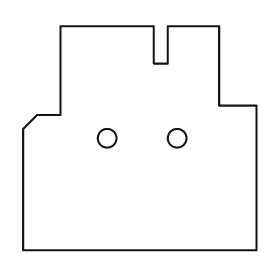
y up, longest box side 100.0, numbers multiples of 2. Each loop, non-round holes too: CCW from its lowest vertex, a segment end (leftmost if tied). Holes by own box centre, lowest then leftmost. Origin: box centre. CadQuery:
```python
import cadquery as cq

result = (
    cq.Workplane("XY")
    .moveTo(-50.0, -48.0)
    .lineTo(50.0, -48.0)
    .lineTo(50.0, 14.0)
    .lineTo(34.0, 14.0)
    .lineTo(34.0, 48.0)
    .lineTo(12.0, 48.0)
    .lineTo(12.0, 32.0)
    .lineTo(6.0, 32.0)
    .lineTo(6.0, 48.0)
    .lineTo(-34.0, 48.0)
    .lineTo(-34.0, 10.0)
    .lineTo(-44.0, 10.0)
    .lineTo(-50.0, 4.0)
    .close()
    .moveTo(-14.0, 0.0)
    .circle(4.0)
    .moveTo(16.0, 0.0)
    .circle(4.0)
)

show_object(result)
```